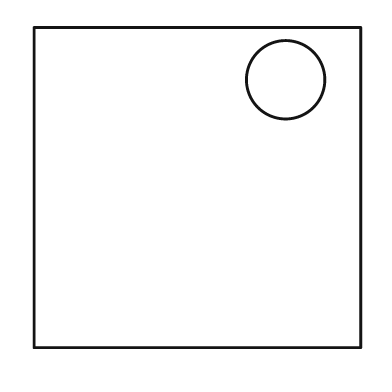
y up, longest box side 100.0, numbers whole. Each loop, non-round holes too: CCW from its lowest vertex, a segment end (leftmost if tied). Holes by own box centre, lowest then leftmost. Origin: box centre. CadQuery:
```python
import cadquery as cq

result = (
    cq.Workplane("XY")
    .moveTo(-50.0, -49.0)
    .lineTo(50.0, -49.0)
    .lineTo(50.0, 49.0)
    .lineTo(-50.0, 49.0)
    .close()
    .moveTo(27.0, 33.0)
    .circle(12.0)
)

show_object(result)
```